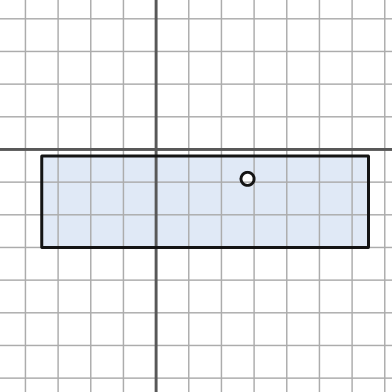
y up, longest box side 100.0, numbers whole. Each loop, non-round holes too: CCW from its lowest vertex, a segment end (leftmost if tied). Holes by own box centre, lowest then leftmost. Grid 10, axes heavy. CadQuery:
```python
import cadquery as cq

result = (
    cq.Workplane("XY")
    .moveTo(-35.0, -30.0)
    .lineTo(65.0, -30.0)
    .lineTo(65.0, -2.0)
    .lineTo(-35.0, -2.0)
    .close()
    .moveTo(28.0, -9.0)
    .circle(2.0)
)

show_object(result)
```